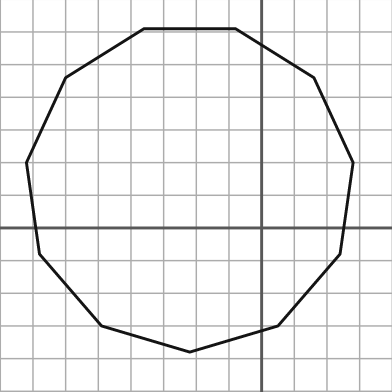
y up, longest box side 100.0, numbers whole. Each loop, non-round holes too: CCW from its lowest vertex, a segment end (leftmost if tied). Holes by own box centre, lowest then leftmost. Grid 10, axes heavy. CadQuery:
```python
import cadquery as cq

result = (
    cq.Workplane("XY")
    .moveTo(-22.0, -38.0)
    .lineTo(5.0, -30.0)
    .lineTo(24.0, -8.0)
    .lineTo(28.0, 20.0)
    .lineTo(16.0, 46.0)
    .lineTo(-8.0, 61.0)
    .lineTo(-36.0, 61.0)
    .lineTo(-60.0, 46.0)
    .lineTo(-72.0, 20.0)
    .lineTo(-68.0, -8.0)
    .lineTo(-49.0, -30.0)
    .close()
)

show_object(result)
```